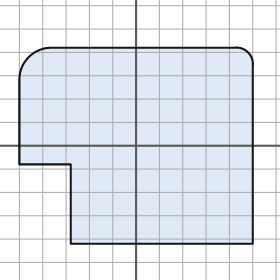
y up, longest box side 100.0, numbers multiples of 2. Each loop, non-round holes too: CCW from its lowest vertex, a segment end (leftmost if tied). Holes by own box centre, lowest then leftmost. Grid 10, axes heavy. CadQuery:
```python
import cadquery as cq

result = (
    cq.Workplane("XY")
    .moveTo(-28.0, -42.0)
    .lineTo(50.0, -42.0)
    .lineTo(50.0, 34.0)
    .threePointArc((48.0, 40.0), (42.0, 42.0))
    .lineTo(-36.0, 42.0)
    .threePointArc((-46.0, 38.0), (-50.0, 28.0))
    .lineTo(-50.0, -8.0)
    .lineTo(-28.0, -8.0)
    .close()
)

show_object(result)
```